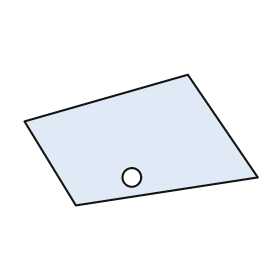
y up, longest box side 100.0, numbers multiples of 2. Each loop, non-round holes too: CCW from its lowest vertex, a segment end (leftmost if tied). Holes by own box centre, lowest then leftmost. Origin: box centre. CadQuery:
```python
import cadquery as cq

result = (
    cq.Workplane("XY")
    .moveTo(-28.0, -28.0)
    .lineTo(50.0, -16.0)
    .lineTo(20.0, 28.0)
    .lineTo(-50.0, 8.0)
    .close()
    .moveTo(-4.0, -16.0)
    .circle(4.0)
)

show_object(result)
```